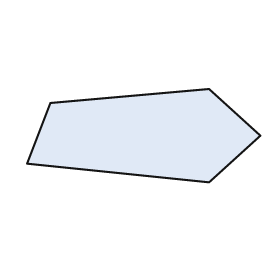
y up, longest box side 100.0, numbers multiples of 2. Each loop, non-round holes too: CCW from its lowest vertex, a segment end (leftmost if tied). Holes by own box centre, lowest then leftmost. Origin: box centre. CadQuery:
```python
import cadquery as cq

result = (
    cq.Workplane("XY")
    .moveTo(28.0, -20.0)
    .lineTo(50.0, 0.0)
    .lineTo(28.0, 20.0)
    .lineTo(-40.0, 14.0)
    .lineTo(-50.0, -12.0)
    .close()
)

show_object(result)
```